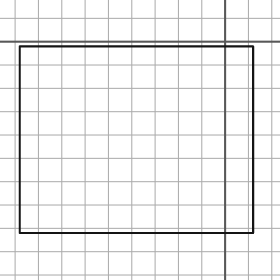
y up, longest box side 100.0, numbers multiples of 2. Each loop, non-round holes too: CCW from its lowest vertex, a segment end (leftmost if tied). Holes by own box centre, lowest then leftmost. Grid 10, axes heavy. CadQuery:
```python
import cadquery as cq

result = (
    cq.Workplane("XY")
    .moveTo(-88.0, -82.0)
    .lineTo(12.0, -82.0)
    .lineTo(12.0, -2.0)
    .lineTo(-88.0, -2.0)
    .close()
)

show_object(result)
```